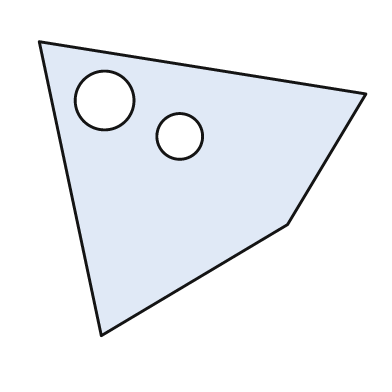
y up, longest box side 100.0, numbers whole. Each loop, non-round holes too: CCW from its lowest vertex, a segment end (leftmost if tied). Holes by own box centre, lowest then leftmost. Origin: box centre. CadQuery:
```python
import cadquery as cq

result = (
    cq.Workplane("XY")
    .moveTo(-31.0, -45.0)
    .lineTo(26.0, -11.0)
    .lineTo(50.0, 29.0)
    .lineTo(-50.0, 45.0)
    .close()
    .moveTo(-7.0, 16.0)
    .circle(7.0)
    .moveTo(-30.0, 27.0)
    .circle(9.0)
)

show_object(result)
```